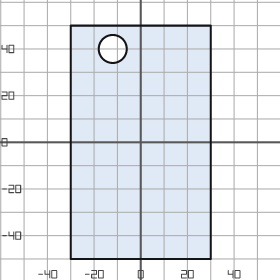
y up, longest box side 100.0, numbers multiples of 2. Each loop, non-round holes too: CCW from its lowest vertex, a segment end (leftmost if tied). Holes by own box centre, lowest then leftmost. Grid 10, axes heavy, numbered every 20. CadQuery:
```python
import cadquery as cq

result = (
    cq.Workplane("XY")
    .moveTo(-30.0, -50.0)
    .lineTo(30.0, -50.0)
    .lineTo(30.0, 50.0)
    .lineTo(-30.0, 50.0)
    .close()
    .moveTo(-12.0, 40.0)
    .circle(6.0)
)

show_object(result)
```